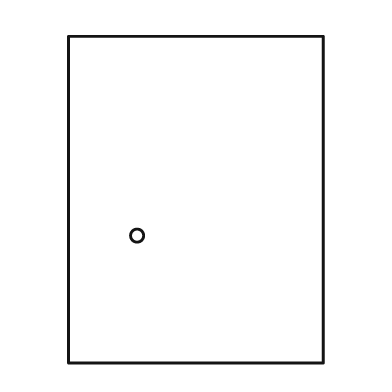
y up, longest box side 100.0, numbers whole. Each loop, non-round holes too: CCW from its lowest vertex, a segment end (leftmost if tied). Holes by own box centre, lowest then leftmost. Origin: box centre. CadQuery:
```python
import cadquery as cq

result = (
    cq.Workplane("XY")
    .moveTo(-39.0, -50.0)
    .lineTo(39.0, -50.0)
    .lineTo(39.0, 50.0)
    .lineTo(-39.0, 50.0)
    .close()
    .moveTo(-18.0, -11.0)
    .circle(2.0)
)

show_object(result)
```